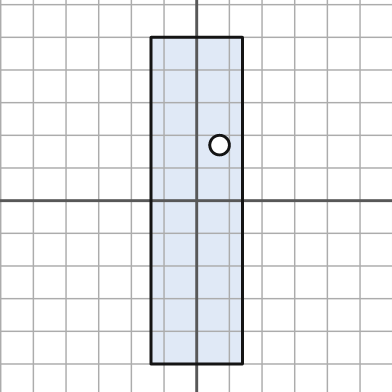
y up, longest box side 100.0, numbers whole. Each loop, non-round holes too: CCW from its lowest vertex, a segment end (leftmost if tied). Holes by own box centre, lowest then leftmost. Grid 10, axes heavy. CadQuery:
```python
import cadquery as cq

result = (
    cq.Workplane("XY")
    .moveTo(-14.0, -50.0)
    .lineTo(14.0, -50.0)
    .lineTo(14.0, 50.0)
    .lineTo(-14.0, 50.0)
    .close()
    .moveTo(7.0, 17.0)
    .circle(3.0)
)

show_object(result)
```